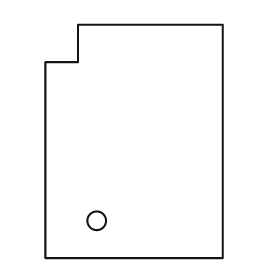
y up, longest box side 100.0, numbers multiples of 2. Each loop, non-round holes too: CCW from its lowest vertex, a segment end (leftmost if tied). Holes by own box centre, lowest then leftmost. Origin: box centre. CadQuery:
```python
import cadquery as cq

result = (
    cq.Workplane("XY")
    .moveTo(-38.0, -50.0)
    .lineTo(38.0, -50.0)
    .lineTo(38.0, 50.0)
    .lineTo(-24.0, 50.0)
    .lineTo(-24.0, 34.0)
    .lineTo(-38.0, 34.0)
    .close()
    .moveTo(-16.0, -34.0)
    .circle(4.0)
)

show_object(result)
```